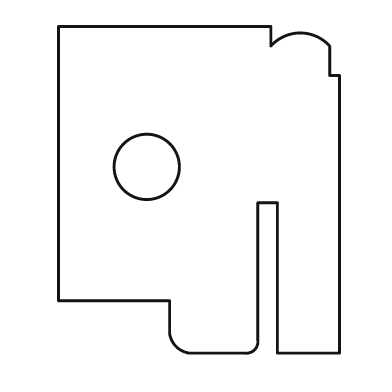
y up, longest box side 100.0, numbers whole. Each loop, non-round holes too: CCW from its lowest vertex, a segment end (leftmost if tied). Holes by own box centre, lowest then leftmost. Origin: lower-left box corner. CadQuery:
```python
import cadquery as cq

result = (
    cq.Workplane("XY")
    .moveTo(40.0, 0.0)
    .lineTo(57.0, 0.0)
    .threePointArc((60.0, 1.0), (61.0, 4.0))
    .lineTo(61.0, 46.0)
    .lineTo(67.0, 46.0)
    .lineTo(67.0, 0.0)
    .lineTo(86.0, 0.0)
    .lineTo(86.0, 85.0)
    .lineTo(83.0, 85.0)
    .lineTo(83.0, 94.0)
    .threePointArc((74.0, 98.0), (65.0, 94.0))
    .lineTo(65.0, 100.0)
    .lineTo(0.0, 100.0)
    .lineTo(0.0, 16.0)
    .lineTo(34.0, 16.0)
    .lineTo(34.0, 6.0)
    .threePointArc((36.0, 2.0), (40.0, 0.0))
    .close()
    .moveTo(27.0, 57.0)
    .circle(10.0)
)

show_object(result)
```